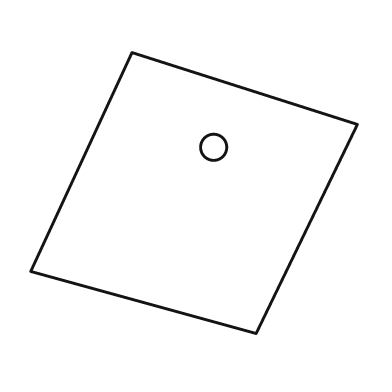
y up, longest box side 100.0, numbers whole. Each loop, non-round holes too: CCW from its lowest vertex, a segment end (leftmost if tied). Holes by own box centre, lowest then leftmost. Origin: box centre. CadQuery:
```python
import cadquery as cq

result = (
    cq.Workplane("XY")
    .moveTo(19.0, -43.0)
    .lineTo(50.0, 21.0)
    .lineTo(-19.0, 43.0)
    .lineTo(-50.0, -24.0)
    .close()
    .moveTo(6.0, 14.0)
    .circle(4.0)
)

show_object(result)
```